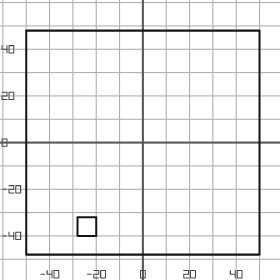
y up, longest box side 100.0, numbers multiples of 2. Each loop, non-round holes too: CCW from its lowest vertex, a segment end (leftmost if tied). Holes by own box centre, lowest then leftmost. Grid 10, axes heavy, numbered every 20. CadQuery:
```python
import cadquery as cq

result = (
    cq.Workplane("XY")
    .moveTo(-50.0, -48.0)
    .lineTo(50.0, -48.0)
    .lineTo(50.0, 48.0)
    .lineTo(-50.0, 48.0)
    .close()
    .moveTo(-28.0, -40.0)
    .lineTo(-20.0, -40.0)
    .lineTo(-20.0, -32.0)
    .lineTo(-28.0, -32.0)
    .close()
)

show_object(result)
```